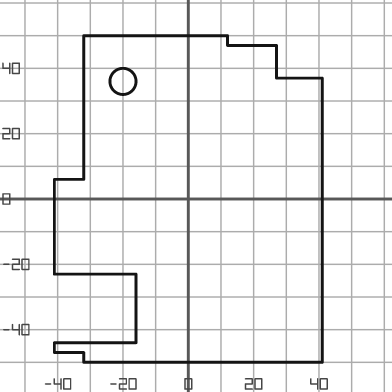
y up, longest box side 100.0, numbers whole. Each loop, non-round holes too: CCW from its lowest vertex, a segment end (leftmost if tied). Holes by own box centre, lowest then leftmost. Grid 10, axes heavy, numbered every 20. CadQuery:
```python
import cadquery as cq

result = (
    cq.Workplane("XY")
    .moveTo(-32.0, -50.0)
    .lineTo(41.0, -50.0)
    .lineTo(41.0, 37.0)
    .lineTo(27.0, 37.0)
    .lineTo(27.0, 47.0)
    .lineTo(12.0, 47.0)
    .lineTo(12.0, 50.0)
    .lineTo(-32.0, 50.0)
    .lineTo(-32.0, 6.0)
    .lineTo(-41.0, 6.0)
    .lineTo(-41.0, -23.0)
    .lineTo(-16.0, -23.0)
    .lineTo(-16.0, -44.0)
    .lineTo(-41.0, -44.0)
    .lineTo(-41.0, -47.0)
    .lineTo(-32.0, -47.0)
    .close()
    .moveTo(-20.0, 36.0)
    .circle(4.0)
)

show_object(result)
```